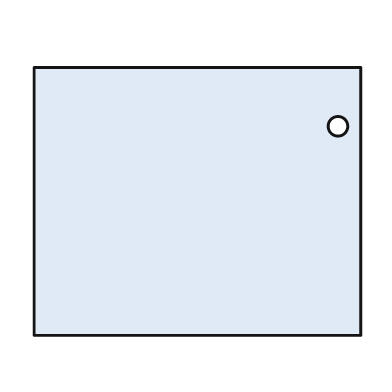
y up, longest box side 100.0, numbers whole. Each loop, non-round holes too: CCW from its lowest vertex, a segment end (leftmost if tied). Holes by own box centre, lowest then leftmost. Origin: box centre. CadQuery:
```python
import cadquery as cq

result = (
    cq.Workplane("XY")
    .moveTo(-50.0, -41.0)
    .lineTo(50.0, -41.0)
    .lineTo(50.0, 41.0)
    .lineTo(-50.0, 41.0)
    .close()
    .moveTo(43.0, 23.0)
    .circle(3.0)
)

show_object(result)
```